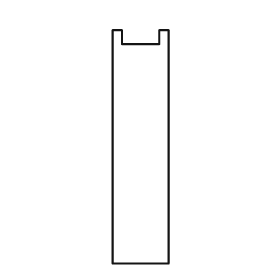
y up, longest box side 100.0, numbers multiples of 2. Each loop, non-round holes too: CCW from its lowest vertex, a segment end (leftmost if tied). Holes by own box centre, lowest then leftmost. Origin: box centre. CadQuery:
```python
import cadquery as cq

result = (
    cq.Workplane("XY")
    .moveTo(-12.0, -50.0)
    .lineTo(12.0, -50.0)
    .lineTo(12.0, 50.0)
    .lineTo(8.0, 50.0)
    .lineTo(8.0, 44.0)
    .lineTo(-8.0, 44.0)
    .lineTo(-8.0, 50.0)
    .lineTo(-12.0, 50.0)
    .close()
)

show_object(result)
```